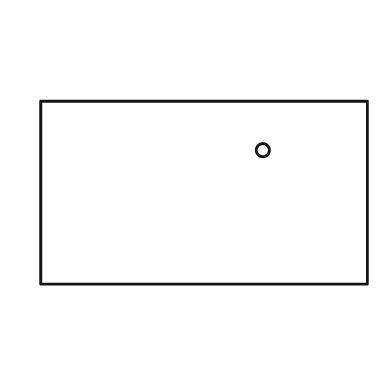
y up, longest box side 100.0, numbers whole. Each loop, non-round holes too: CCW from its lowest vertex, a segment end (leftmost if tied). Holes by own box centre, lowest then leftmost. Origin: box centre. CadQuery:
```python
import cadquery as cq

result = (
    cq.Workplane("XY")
    .moveTo(-50.0, -28.0)
    .lineTo(50.0, -28.0)
    .lineTo(50.0, 28.0)
    .lineTo(-50.0, 28.0)
    .close()
    .moveTo(18.0, 13.0)
    .circle(2.0)
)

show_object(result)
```